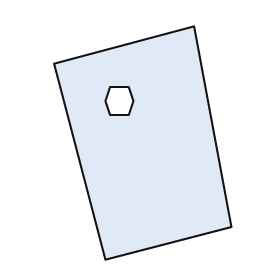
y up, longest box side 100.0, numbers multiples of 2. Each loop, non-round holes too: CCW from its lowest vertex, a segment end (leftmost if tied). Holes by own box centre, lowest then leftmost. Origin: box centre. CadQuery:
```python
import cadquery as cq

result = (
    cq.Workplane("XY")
    .moveTo(-16.0, -50.0)
    .lineTo(38.0, -36.0)
    .lineTo(22.0, 50.0)
    .lineTo(-38.0, 34.0)
    .close()
    .moveTo(-14.0, 12.0)
    .lineTo(-6.0, 12.0)
    .lineTo(-4.0, 18.0)
    .lineTo(-6.0, 24.0)
    .lineTo(-14.0, 24.0)
    .lineTo(-16.0, 18.0)
    .close()
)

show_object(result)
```